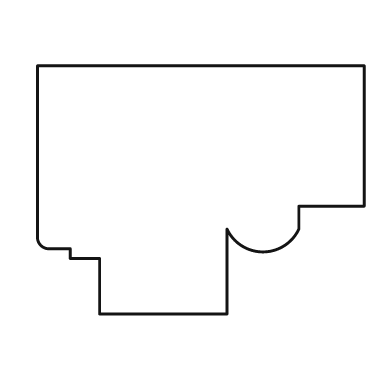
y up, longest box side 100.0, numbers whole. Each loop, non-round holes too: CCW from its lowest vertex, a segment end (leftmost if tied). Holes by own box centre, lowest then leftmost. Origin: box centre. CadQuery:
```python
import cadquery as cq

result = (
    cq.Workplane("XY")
    .moveTo(-31.0, -38.0)
    .lineTo(8.0, -38.0)
    .lineTo(8.0, -12.0)
    .threePointArc((19.0, -19.0), (30.0, -12.0))
    .lineTo(30.0, -5.0)
    .lineTo(50.0, -5.0)
    .lineTo(50.0, 38.0)
    .lineTo(-50.0, 38.0)
    .lineTo(-50.0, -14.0)
    .threePointArc((-49.0, -17.0), (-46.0, -18.0))
    .lineTo(-40.0, -18.0)
    .lineTo(-40.0, -21.0)
    .lineTo(-31.0, -21.0)
    .close()
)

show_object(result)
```